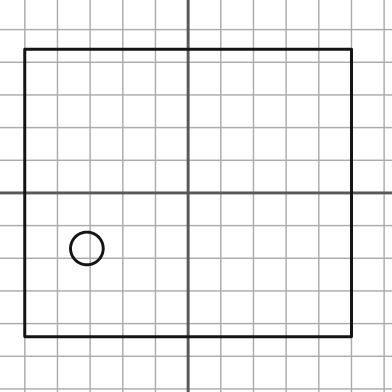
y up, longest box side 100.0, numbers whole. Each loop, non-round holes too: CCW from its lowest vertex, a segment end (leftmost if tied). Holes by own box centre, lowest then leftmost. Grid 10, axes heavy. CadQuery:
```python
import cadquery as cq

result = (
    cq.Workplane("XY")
    .moveTo(-50.0, -44.0)
    .lineTo(50.0, -44.0)
    .lineTo(50.0, 44.0)
    .lineTo(-50.0, 44.0)
    .close()
    .moveTo(-31.0, -17.0)
    .circle(5.0)
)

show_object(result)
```